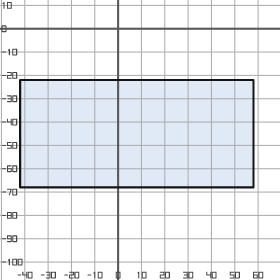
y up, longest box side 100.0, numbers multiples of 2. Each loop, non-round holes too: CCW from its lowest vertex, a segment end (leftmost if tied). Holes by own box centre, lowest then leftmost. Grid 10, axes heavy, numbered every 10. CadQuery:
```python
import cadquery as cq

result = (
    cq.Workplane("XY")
    .moveTo(-42.0, -68.0)
    .lineTo(58.0, -68.0)
    .lineTo(58.0, -22.0)
    .lineTo(-42.0, -22.0)
    .close()
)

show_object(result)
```